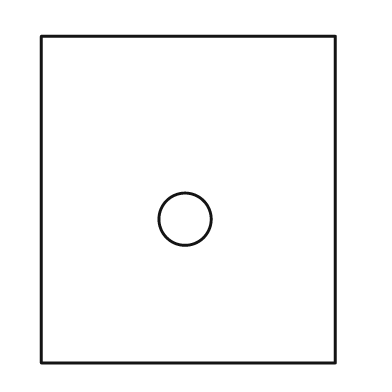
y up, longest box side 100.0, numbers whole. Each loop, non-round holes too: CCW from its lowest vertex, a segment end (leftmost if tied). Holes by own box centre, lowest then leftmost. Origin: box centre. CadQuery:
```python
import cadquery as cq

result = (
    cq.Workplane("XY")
    .moveTo(-45.0, -50.0)
    .lineTo(45.0, -50.0)
    .lineTo(45.0, 50.0)
    .lineTo(-45.0, 50.0)
    .close()
    .moveTo(-1.0, -6.0)
    .circle(8.0)
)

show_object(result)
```